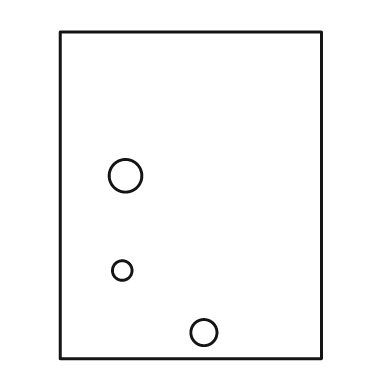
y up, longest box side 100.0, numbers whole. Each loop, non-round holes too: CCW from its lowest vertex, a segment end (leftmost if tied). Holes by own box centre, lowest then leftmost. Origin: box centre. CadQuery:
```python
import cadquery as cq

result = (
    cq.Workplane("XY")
    .moveTo(-40.0, -50.0)
    .lineTo(40.0, -50.0)
    .lineTo(40.0, 50.0)
    .lineTo(-40.0, 50.0)
    .close()
    .moveTo(4.0, -42.0)
    .circle(4.0)
    .moveTo(-21.0, -23.0)
    .circle(3.0)
    .moveTo(-20.0, 6.0)
    .circle(5.0)
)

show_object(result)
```